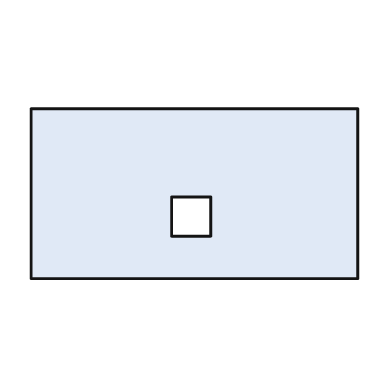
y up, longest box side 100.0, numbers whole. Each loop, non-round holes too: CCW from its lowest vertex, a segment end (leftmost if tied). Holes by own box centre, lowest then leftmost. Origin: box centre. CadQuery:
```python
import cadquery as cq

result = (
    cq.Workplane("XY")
    .moveTo(-50.0, -26.0)
    .lineTo(50.0, -26.0)
    .lineTo(50.0, 26.0)
    .lineTo(-50.0, 26.0)
    .close()
    .moveTo(-7.0, -13.0)
    .lineTo(5.0, -13.0)
    .lineTo(5.0, -1.0)
    .lineTo(-7.0, -1.0)
    .close()
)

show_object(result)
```